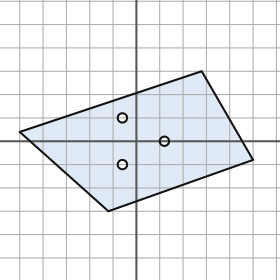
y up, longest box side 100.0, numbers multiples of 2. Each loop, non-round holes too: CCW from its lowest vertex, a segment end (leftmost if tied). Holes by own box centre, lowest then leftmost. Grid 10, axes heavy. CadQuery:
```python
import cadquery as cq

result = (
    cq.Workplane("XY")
    .moveTo(-12.0, -30.0)
    .lineTo(50.0, -8.0)
    .lineTo(28.0, 30.0)
    .lineTo(-50.0, 4.0)
    .close()
    .moveTo(-6.0, -10.0)
    .circle(2.0)
    .moveTo(12.0, 0.0)
    .circle(2.0)
    .moveTo(-6.0, 10.0)
    .circle(2.0)
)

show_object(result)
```